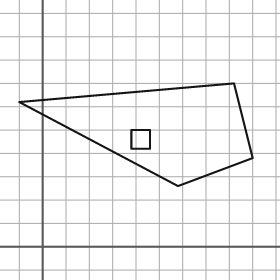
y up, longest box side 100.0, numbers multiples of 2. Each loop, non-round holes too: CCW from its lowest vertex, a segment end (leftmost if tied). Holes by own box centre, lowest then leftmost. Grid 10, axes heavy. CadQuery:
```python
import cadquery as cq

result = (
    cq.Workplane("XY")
    .moveTo(58.0, 26.0)
    .lineTo(90.0, 38.0)
    .lineTo(82.0, 70.0)
    .lineTo(-10.0, 62.0)
    .close()
    .moveTo(38.0, 42.0)
    .lineTo(46.0, 42.0)
    .lineTo(46.0, 50.0)
    .lineTo(38.0, 50.0)
    .close()
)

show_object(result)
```